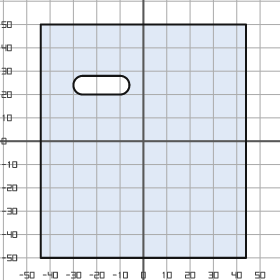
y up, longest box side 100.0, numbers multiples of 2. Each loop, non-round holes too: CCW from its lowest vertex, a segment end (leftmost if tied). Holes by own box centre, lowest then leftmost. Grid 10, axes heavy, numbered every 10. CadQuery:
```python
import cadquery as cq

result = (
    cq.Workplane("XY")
    .moveTo(-44.0, -50.0)
    .lineTo(44.0, -50.0)
    .lineTo(44.0, 50.0)
    .lineTo(-44.0, 50.0)
    .close()
    .moveTo(-26.0, 20.0)
    .lineTo(-10.0, 20.0)
    .threePointArc((-6.0, 24.0), (-10.0, 28.0))
    .lineTo(-26.0, 28.0)
    .threePointArc((-30.0, 24.0), (-26.0, 20.0))
    .close()
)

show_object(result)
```